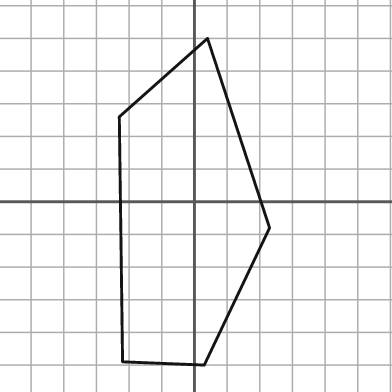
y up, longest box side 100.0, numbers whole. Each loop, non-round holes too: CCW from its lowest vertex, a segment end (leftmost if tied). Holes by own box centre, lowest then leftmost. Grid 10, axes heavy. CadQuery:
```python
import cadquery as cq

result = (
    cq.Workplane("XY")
    .moveTo(3.0, -50.0)
    .lineTo(23.0, -8.0)
    .lineTo(4.0, 50.0)
    .lineTo(-23.0, 26.0)
    .lineTo(-22.0, -49.0)
    .close()
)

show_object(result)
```